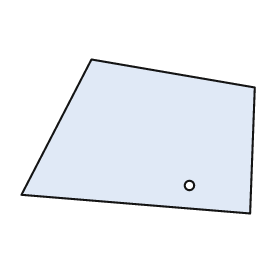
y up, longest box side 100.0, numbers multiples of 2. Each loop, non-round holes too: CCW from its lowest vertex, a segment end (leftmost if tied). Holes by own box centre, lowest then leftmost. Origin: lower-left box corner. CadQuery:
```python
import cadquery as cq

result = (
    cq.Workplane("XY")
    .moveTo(98.0, 0.0)
    .lineTo(100.0, 54.0)
    .lineTo(30.0, 66.0)
    .lineTo(0.0, 8.0)
    .close()
    .moveTo(72.0, 12.0)
    .circle(2.0)
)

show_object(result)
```